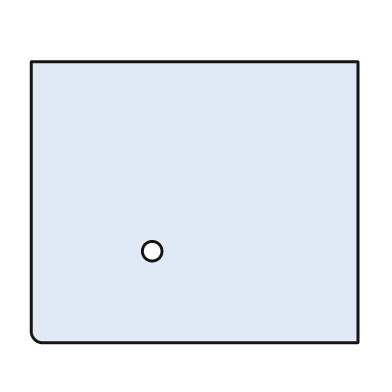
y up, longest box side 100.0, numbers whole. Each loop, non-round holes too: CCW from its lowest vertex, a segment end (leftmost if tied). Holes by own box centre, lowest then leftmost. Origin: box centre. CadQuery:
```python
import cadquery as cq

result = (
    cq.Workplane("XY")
    .moveTo(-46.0, -43.0)
    .lineTo(50.0, -43.0)
    .lineTo(50.0, 43.0)
    .lineTo(-50.0, 43.0)
    .lineTo(-50.0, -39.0)
    .threePointArc((-49.0, -42.0), (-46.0, -43.0))
    .close()
    .moveTo(-13.0, -15.0)
    .circle(3.0)
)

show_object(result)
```